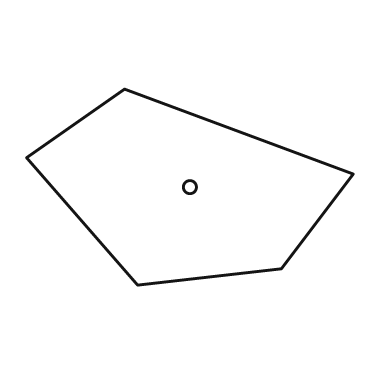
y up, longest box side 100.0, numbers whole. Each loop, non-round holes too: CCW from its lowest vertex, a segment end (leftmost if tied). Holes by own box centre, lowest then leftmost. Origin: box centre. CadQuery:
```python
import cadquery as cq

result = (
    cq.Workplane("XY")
    .moveTo(-16.0, -30.0)
    .lineTo(28.0, -25.0)
    .lineTo(50.0, 4.0)
    .lineTo(-20.0, 30.0)
    .lineTo(-50.0, 9.0)
    .close()
    .moveTo(0.0, 0.0)
    .circle(2.0)
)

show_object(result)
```